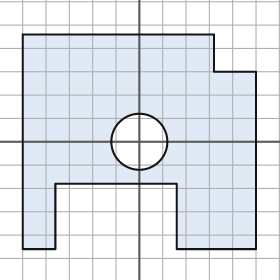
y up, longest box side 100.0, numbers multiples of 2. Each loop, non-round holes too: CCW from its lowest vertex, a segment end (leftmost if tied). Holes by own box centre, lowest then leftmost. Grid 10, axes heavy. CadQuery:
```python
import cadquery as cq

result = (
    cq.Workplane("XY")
    .moveTo(-50.0, -46.0)
    .lineTo(-36.0, -46.0)
    .lineTo(-36.0, -18.0)
    .lineTo(16.0, -18.0)
    .lineTo(16.0, -46.0)
    .lineTo(50.0, -46.0)
    .lineTo(50.0, 30.0)
    .lineTo(32.0, 30.0)
    .lineTo(32.0, 46.0)
    .lineTo(-50.0, 46.0)
    .close()
    .moveTo(0.0, 0.0)
    .circle(12.0)
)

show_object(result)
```